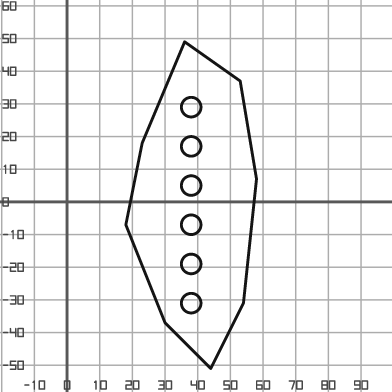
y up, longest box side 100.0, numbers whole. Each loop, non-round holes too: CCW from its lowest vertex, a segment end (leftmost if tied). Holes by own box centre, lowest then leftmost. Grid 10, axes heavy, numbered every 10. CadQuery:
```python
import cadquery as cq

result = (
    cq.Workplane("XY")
    .moveTo(44.0, -51.0)
    .lineTo(54.0, -31.0)
    .lineTo(58.0, 7.0)
    .lineTo(53.0, 37.0)
    .lineTo(36.0, 49.0)
    .lineTo(23.0, 18.0)
    .lineTo(18.0, -7.0)
    .lineTo(30.0, -37.0)
    .close()
    .moveTo(38.0, -31.0)
    .circle(3.0)
    .moveTo(38.0, -19.0)
    .circle(3.0)
    .moveTo(38.0, -7.0)
    .circle(3.0)
    .moveTo(38.0, 5.0)
    .circle(3.0)
    .moveTo(38.0, 17.0)
    .circle(3.0)
    .moveTo(38.0, 29.0)
    .circle(3.0)
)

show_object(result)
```